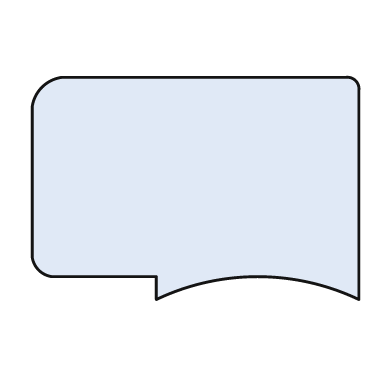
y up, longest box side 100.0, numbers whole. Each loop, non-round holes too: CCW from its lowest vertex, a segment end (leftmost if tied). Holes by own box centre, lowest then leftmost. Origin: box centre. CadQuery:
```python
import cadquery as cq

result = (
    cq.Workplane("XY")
    .moveTo(-12.0, -34.0)
    .threePointArc((19.0, -27.0), (50.0, -34.0))
    .lineTo(50.0, 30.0)
    .threePointArc((49.0, 33.0), (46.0, 34.0))
    .lineTo(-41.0, 34.0)
    .threePointArc((-47.0, 31.0), (-50.0, 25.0))
    .lineTo(-50.0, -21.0)
    .threePointArc((-48.0, -25.0), (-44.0, -27.0))
    .lineTo(-12.0, -27.0)
    .close()
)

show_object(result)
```